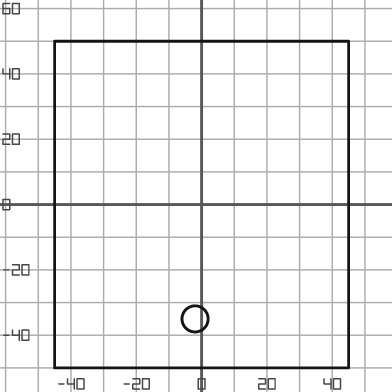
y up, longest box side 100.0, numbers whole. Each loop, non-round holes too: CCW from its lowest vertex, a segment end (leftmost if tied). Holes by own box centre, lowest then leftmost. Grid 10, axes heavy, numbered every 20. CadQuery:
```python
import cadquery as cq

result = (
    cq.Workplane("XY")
    .moveTo(-45.0, -50.0)
    .lineTo(45.0, -50.0)
    .lineTo(45.0, 50.0)
    .lineTo(-45.0, 50.0)
    .close()
    .moveTo(-2.0, -35.0)
    .circle(4.0)
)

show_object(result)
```